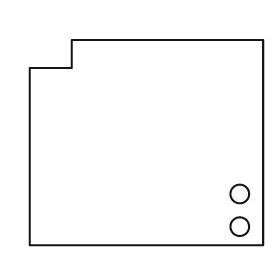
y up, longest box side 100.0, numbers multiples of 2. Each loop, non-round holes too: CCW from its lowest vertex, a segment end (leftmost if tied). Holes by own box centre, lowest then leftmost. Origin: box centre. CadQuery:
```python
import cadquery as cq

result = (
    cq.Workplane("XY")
    .moveTo(-50.0, -44.0)
    .lineTo(50.0, -44.0)
    .lineTo(50.0, 44.0)
    .lineTo(-32.0, 44.0)
    .lineTo(-32.0, 32.0)
    .lineTo(-50.0, 32.0)
    .close()
    .moveTo(40.0, -36.0)
    .circle(4.0)
    .moveTo(40.0, -22.0)
    .circle(4.0)
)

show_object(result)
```